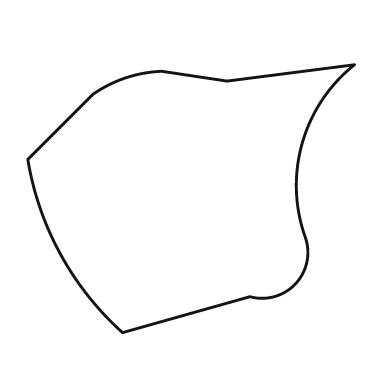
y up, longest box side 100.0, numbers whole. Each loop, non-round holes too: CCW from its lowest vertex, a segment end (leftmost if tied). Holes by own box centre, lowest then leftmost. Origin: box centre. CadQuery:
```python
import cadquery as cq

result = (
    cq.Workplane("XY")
    .moveTo(-21.0, -41.0)
    .lineTo(18.0, -30.0)
    .threePointArc((32.0, -26.0), (35.0, -12.0))
    .threePointArc((34.0, 17.0), (50.0, 41.0))
    .lineTo(11.0, 36.0)
    .lineTo(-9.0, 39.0)
    .threePointArc((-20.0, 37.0), (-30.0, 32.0))
    .lineTo(-50.0, 12.0)
    .threePointArc((-40.0, -17.0), (-21.0, -41.0))
    .close()
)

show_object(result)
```